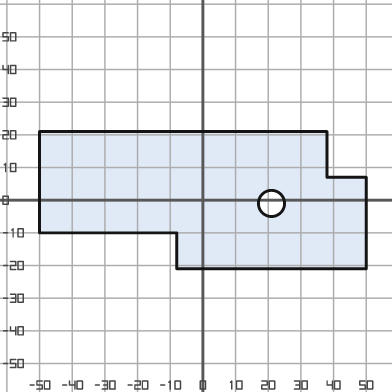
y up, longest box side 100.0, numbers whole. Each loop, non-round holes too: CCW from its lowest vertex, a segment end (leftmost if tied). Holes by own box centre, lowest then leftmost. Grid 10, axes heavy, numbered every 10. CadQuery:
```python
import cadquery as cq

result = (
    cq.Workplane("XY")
    .moveTo(-8.0, -21.0)
    .lineTo(50.0, -21.0)
    .lineTo(50.0, 7.0)
    .lineTo(38.0, 7.0)
    .lineTo(38.0, 21.0)
    .lineTo(-50.0, 21.0)
    .lineTo(-50.0, -10.0)
    .lineTo(-8.0, -10.0)
    .close()
    .moveTo(21.0, -1.0)
    .circle(4.0)
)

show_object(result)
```